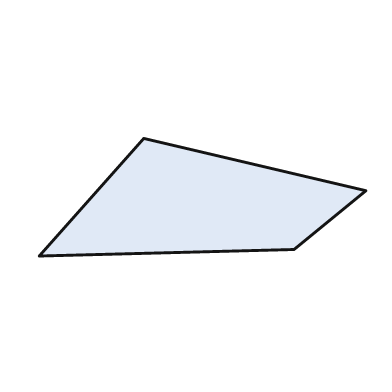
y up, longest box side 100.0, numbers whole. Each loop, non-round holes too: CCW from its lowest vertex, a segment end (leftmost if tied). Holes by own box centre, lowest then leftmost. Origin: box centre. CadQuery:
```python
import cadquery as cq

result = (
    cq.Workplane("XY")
    .moveTo(-50.0, -18.0)
    .lineTo(28.0, -16.0)
    .lineTo(50.0, 2.0)
    .lineTo(-18.0, 18.0)
    .close()
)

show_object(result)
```